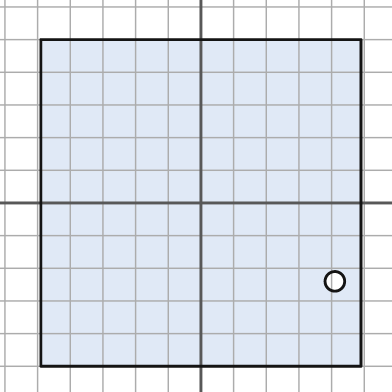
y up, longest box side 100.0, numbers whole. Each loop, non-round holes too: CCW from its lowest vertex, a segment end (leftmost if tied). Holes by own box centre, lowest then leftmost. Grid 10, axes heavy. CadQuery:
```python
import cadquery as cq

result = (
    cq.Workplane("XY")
    .moveTo(-49.0, -50.0)
    .lineTo(49.0, -50.0)
    .lineTo(49.0, 50.0)
    .lineTo(-49.0, 50.0)
    .close()
    .moveTo(41.0, -24.0)
    .circle(3.0)
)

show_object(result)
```